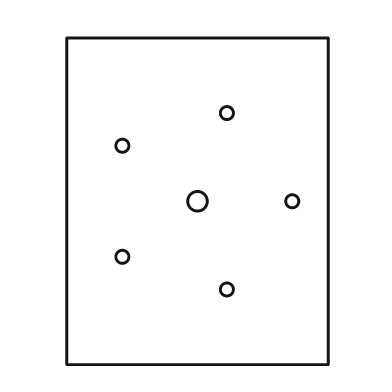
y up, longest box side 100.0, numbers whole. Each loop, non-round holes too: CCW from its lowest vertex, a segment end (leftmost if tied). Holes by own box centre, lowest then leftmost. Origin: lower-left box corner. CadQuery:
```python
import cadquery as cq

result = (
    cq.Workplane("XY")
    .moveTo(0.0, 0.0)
    .lineTo(80.0, 0.0)
    .lineTo(80.0, 100.0)
    .lineTo(0.0, 100.0)
    .close()
    .moveTo(49.0, 23.0)
    .circle(2.0)
    .moveTo(17.0, 33.0)
    .circle(2.0)
    .moveTo(40.0, 50.0)
    .circle(3.0)
    .moveTo(69.0, 50.0)
    .circle(2.0)
    .moveTo(17.0, 67.0)
    .circle(2.0)
    .moveTo(49.0, 77.0)
    .circle(2.0)
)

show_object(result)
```